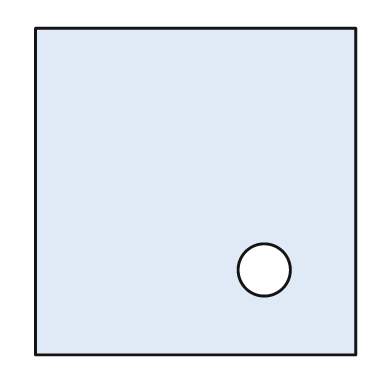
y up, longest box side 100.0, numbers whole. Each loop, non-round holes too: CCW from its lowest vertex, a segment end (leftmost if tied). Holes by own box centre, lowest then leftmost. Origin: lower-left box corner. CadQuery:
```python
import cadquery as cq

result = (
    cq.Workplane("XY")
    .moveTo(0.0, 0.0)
    .lineTo(98.0, 0.0)
    .lineTo(98.0, 100.0)
    .lineTo(0.0, 100.0)
    .close()
    .moveTo(70.0, 26.0)
    .circle(8.0)
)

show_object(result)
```